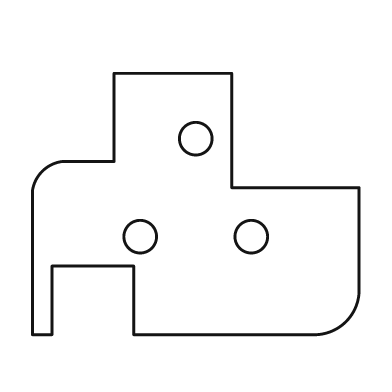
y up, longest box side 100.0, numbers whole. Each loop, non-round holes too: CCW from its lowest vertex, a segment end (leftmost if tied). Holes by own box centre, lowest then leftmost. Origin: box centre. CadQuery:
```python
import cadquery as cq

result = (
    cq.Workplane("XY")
    .moveTo(-50.0, -40.0)
    .lineTo(-44.0, -40.0)
    .lineTo(-44.0, -19.0)
    .lineTo(-19.0, -19.0)
    .lineTo(-19.0, -40.0)
    .lineTo(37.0, -40.0)
    .threePointArc((46.0, -36.0), (50.0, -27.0))
    .lineTo(50.0, 5.0)
    .lineTo(11.0, 5.0)
    .lineTo(11.0, 40.0)
    .lineTo(-25.0, 40.0)
    .lineTo(-25.0, 13.0)
    .lineTo(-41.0, 13.0)
    .threePointArc((-47.0, 10.0), (-50.0, 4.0))
    .close()
    .moveTo(-17.0, -10.0)
    .circle(5.0)
    .moveTo(17.0, -10.0)
    .circle(5.0)
    .moveTo(0.0, 20.0)
    .circle(5.0)
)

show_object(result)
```